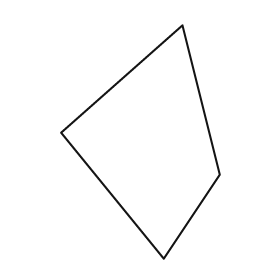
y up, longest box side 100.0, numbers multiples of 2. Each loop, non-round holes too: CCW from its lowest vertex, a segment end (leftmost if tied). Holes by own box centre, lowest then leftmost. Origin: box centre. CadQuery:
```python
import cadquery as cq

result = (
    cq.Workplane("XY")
    .moveTo(10.0, -50.0)
    .lineTo(34.0, -14.0)
    .lineTo(18.0, 50.0)
    .lineTo(-34.0, 4.0)
    .close()
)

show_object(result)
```